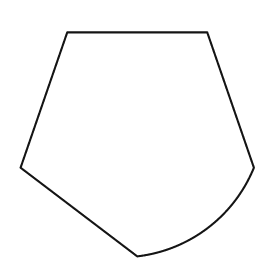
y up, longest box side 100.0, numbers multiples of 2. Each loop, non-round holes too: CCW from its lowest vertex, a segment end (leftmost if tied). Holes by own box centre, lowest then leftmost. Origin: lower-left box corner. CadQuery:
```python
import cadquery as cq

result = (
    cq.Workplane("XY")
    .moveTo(50.0, 0.0)
    .threePointArc((80.0, 12.0), (100.0, 38.0))
    .lineTo(80.0, 96.0)
    .lineTo(20.0, 96.0)
    .lineTo(0.0, 38.0)
    .close()
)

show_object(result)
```